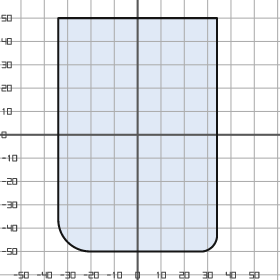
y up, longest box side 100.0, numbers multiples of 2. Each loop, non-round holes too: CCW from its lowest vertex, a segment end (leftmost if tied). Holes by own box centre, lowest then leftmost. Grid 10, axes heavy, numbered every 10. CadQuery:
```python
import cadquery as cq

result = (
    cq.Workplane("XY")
    .moveTo(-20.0, -50.0)
    .lineTo(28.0, -50.0)
    .threePointArc((32.0, -48.0), (34.0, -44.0))
    .lineTo(34.0, 50.0)
    .lineTo(-34.0, 50.0)
    .lineTo(-34.0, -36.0)
    .threePointArc((-30.0, -46.0), (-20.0, -50.0))
    .close()
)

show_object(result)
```